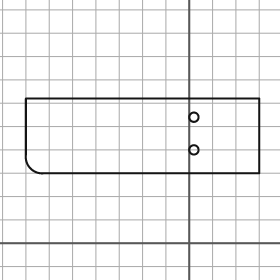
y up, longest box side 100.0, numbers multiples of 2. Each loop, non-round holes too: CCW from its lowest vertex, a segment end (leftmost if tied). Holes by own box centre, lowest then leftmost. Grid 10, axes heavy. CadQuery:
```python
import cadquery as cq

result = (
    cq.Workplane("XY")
    .moveTo(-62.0, 30.0)
    .lineTo(30.0, 30.0)
    .lineTo(30.0, 62.0)
    .lineTo(-70.0, 62.0)
    .lineTo(-70.0, 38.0)
    .threePointArc((-68.0, 32.0), (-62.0, 30.0))
    .close()
    .moveTo(2.0, 40.0)
    .circle(2.0)
    .moveTo(2.0, 54.0)
    .circle(2.0)
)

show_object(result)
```